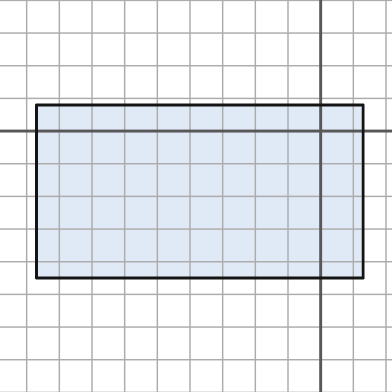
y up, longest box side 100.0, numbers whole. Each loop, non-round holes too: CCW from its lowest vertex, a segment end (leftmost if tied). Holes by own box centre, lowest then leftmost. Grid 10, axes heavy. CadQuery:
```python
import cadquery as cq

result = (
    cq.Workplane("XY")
    .moveTo(-87.0, -45.0)
    .lineTo(13.0, -45.0)
    .lineTo(13.0, 8.0)
    .lineTo(-87.0, 8.0)
    .close()
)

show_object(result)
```